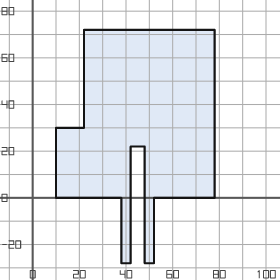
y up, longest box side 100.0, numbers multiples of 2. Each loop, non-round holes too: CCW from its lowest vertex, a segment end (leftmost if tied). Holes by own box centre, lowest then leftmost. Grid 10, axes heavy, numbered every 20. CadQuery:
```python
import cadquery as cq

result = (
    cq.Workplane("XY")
    .moveTo(38.0, -28.0)
    .lineTo(42.0, -28.0)
    .lineTo(42.0, 22.0)
    .lineTo(48.0, 22.0)
    .lineTo(48.0, -28.0)
    .lineTo(52.0, -28.0)
    .lineTo(52.0, 0.0)
    .lineTo(78.0, 0.0)
    .lineTo(78.0, 72.0)
    .lineTo(22.0, 72.0)
    .lineTo(22.0, 30.0)
    .lineTo(10.0, 30.0)
    .lineTo(10.0, 0.0)
    .lineTo(38.0, 0.0)
    .close()
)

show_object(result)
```